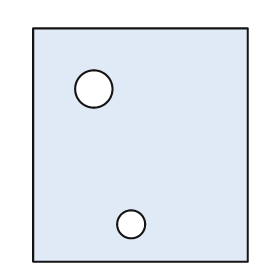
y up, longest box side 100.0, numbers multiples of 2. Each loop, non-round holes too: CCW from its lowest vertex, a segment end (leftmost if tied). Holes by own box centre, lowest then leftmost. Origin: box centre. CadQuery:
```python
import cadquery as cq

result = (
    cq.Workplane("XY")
    .moveTo(-46.0, -50.0)
    .lineTo(46.0, -50.0)
    .lineTo(46.0, 50.0)
    .lineTo(-46.0, 50.0)
    .close()
    .moveTo(-4.0, -34.0)
    .circle(6.0)
    .moveTo(-20.0, 24.0)
    .circle(8.0)
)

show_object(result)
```